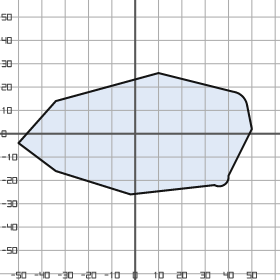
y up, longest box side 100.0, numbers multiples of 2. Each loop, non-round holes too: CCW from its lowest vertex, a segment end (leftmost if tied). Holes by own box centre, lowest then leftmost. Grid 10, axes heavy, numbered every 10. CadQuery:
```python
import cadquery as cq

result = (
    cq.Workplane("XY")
    .moveTo(-2.0, -26.0)
    .lineTo(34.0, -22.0)
    .threePointArc((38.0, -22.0), (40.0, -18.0))
    .lineTo(50.0, 2.0)
    .lineTo(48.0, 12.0)
    .threePointArc((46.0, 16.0), (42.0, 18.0))
    .lineTo(10.0, 26.0)
    .lineTo(-34.0, 14.0)
    .lineTo(-50.0, -4.0)
    .lineTo(-34.0, -16.0)
    .close()
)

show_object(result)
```